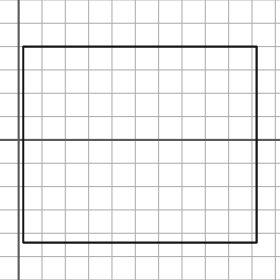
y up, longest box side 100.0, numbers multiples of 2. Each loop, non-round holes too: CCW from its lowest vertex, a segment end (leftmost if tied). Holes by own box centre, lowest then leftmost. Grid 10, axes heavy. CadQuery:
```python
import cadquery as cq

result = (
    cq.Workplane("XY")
    .moveTo(2.0, -44.0)
    .lineTo(102.0, -44.0)
    .lineTo(102.0, 40.0)
    .lineTo(2.0, 40.0)
    .close()
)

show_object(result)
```